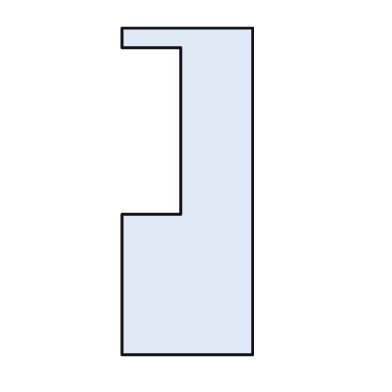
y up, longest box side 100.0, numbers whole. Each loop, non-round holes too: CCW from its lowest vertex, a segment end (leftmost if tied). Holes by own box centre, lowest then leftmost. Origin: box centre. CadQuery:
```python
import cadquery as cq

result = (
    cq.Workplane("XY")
    .moveTo(-20.0, -50.0)
    .lineTo(20.0, -50.0)
    .lineTo(20.0, 50.0)
    .lineTo(-20.0, 50.0)
    .lineTo(-20.0, 44.0)
    .lineTo(-2.0, 44.0)
    .lineTo(-2.0, -7.0)
    .lineTo(-20.0, -7.0)
    .close()
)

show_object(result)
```